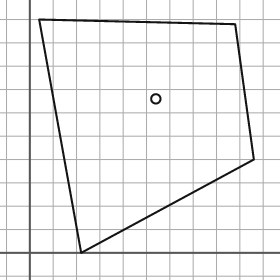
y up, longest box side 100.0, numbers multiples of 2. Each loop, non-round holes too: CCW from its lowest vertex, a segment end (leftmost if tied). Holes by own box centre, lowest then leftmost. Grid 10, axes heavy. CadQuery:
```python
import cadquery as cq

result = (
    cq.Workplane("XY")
    .moveTo(22.0, 0.0)
    .lineTo(96.0, 40.0)
    .lineTo(88.0, 98.0)
    .lineTo(4.0, 100.0)
    .close()
    .moveTo(54.0, 66.0)
    .circle(2.0)
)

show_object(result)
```